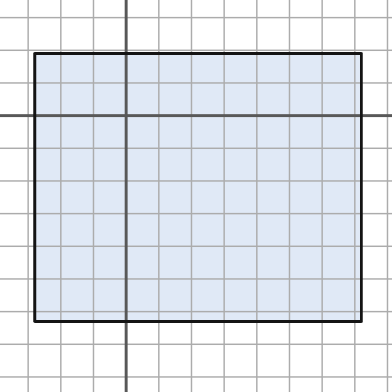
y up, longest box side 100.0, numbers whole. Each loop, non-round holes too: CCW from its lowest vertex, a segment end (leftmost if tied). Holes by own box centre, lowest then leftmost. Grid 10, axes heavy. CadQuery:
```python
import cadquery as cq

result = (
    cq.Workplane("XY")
    .moveTo(-28.0, -63.0)
    .lineTo(72.0, -63.0)
    .lineTo(72.0, 19.0)
    .lineTo(-28.0, 19.0)
    .close()
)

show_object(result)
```